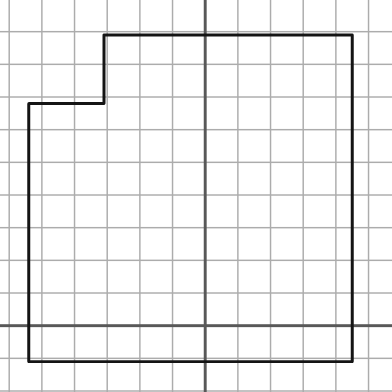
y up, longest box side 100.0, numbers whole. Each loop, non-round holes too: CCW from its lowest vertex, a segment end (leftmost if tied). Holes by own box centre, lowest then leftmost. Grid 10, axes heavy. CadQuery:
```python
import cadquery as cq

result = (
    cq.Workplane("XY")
    .moveTo(-54.0, -11.0)
    .lineTo(45.0, -11.0)
    .lineTo(45.0, 89.0)
    .lineTo(-31.0, 89.0)
    .lineTo(-31.0, 68.0)
    .lineTo(-54.0, 68.0)
    .close()
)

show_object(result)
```